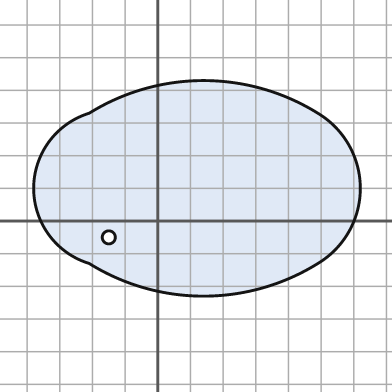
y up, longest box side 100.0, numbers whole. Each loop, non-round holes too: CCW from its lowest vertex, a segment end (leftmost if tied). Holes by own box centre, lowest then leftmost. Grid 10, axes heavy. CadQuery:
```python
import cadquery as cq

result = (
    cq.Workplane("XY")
    .moveTo(-21.0, -13.0)
    .threePointArc((14.0, -23.0), (49.0, -13.0))
    .threePointArc((62.0, 10.0), (49.0, 33.0))
    .threePointArc((14.0, 43.0), (-21.0, 33.0))
    .threePointArc((-38.0, 10.0), (-21.0, -13.0))
    .close()
    .moveTo(-15.0, -5.0)
    .circle(2.0)
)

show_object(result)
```